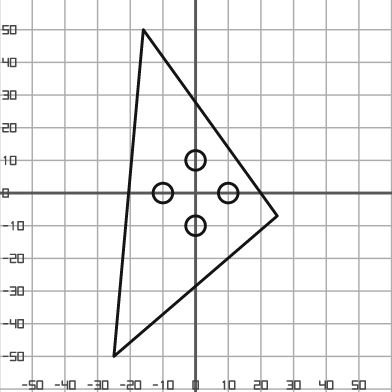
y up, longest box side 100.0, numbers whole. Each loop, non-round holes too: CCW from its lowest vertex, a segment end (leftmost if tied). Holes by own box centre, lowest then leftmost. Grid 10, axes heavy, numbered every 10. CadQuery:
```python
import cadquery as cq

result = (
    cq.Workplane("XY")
    .moveTo(-25.0, -50.0)
    .lineTo(25.0, -7.0)
    .lineTo(-16.0, 50.0)
    .close()
    .moveTo(0.0, -10.0)
    .circle(3.0)
    .moveTo(-10.0, 0.0)
    .circle(3.0)
    .moveTo(10.0, 0.0)
    .circle(3.0)
    .moveTo(0.0, 10.0)
    .circle(3.0)
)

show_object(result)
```